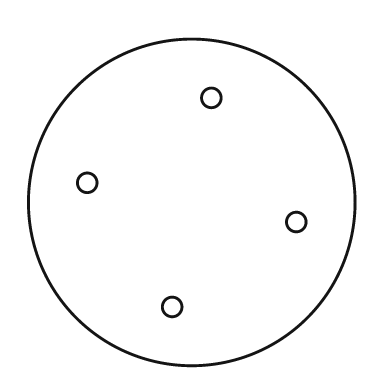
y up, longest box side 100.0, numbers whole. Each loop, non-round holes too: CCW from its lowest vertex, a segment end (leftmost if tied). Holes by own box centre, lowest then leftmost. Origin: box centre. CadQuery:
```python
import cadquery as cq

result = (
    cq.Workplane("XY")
    .moveTo(0.0, 0.0)
    .circle(50.0)
    .moveTo(-6.0, -32.0)
    .circle(3.0)
    .moveTo(32.0, -6.0)
    .circle(3.0)
    .moveTo(-32.0, 6.0)
    .circle(3.0)
    .moveTo(6.0, 32.0)
    .circle(3.0)
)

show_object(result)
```